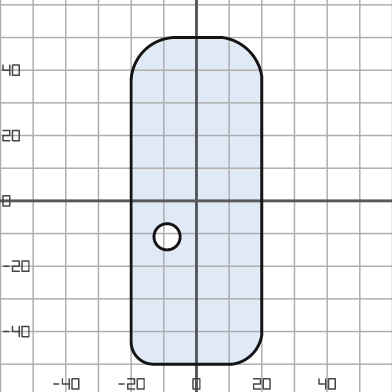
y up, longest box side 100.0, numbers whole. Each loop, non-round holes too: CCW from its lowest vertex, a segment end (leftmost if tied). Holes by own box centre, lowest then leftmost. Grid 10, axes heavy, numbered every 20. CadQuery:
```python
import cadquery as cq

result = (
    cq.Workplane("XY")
    .moveTo(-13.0, -50.0)
    .lineTo(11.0, -50.0)
    .threePointArc((17.0, -47.0), (20.0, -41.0))
    .lineTo(20.0, 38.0)
    .threePointArc((16.0, 46.0), (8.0, 50.0))
    .lineTo(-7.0, 50.0)
    .threePointArc((-16.0, 46.0), (-20.0, 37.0))
    .lineTo(-20.0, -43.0)
    .threePointArc((-18.0, -48.0), (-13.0, -50.0))
    .close()
    .moveTo(-9.0, -11.0)
    .circle(4.0)
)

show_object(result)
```